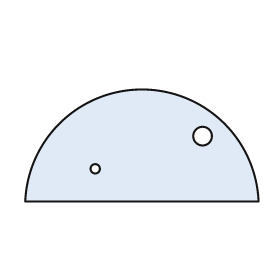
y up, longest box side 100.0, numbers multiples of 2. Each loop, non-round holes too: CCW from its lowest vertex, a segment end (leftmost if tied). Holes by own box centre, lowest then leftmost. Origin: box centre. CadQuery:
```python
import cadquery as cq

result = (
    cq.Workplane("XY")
    .moveTo(-50.0, -24.0)
    .lineTo(50.0, -24.0)
    .threePointArc((0.0, 24.0), (-50.0, -24.0))
    .close()
    .moveTo(-20.0, -10.0)
    .circle(2.0)
    .moveTo(26.0, 4.0)
    .circle(4.0)
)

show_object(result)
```